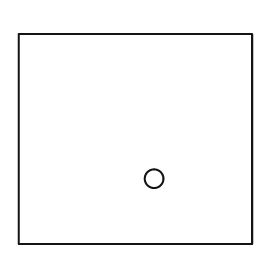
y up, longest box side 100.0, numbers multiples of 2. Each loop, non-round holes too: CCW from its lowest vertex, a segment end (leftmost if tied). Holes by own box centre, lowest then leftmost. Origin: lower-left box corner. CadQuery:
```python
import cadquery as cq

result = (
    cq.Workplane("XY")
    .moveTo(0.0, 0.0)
    .lineTo(100.0, 0.0)
    .lineTo(100.0, 90.0)
    .lineTo(0.0, 90.0)
    .close()
    .moveTo(58.0, 28.0)
    .circle(4.0)
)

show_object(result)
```